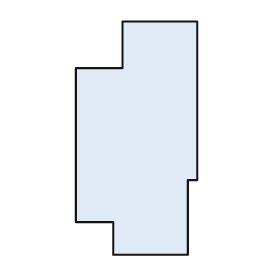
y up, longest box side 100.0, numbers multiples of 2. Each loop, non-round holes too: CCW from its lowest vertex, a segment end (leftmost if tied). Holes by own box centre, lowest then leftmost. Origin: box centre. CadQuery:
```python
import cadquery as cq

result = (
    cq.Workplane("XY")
    .moveTo(-10.0, -50.0)
    .lineTo(22.0, -50.0)
    .lineTo(22.0, -18.0)
    .lineTo(26.0, -18.0)
    .lineTo(26.0, 50.0)
    .lineTo(-6.0, 50.0)
    .lineTo(-6.0, 30.0)
    .lineTo(-26.0, 30.0)
    .lineTo(-26.0, -36.0)
    .lineTo(-10.0, -36.0)
    .close()
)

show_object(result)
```